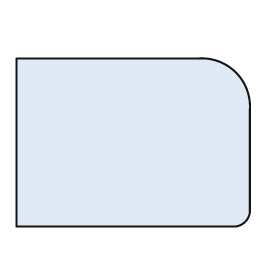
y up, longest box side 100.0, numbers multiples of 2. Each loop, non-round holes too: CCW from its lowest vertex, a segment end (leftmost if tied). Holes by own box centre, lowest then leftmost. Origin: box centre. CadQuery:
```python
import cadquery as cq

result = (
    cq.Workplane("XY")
    .moveTo(-50.0, -36.0)
    .lineTo(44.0, -36.0)
    .threePointArc((48.0, -34.0), (50.0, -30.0))
    .lineTo(50.0, 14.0)
    .threePointArc((44.0, 30.0), (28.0, 36.0))
    .lineTo(-50.0, 36.0)
    .close()
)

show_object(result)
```